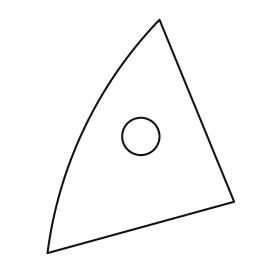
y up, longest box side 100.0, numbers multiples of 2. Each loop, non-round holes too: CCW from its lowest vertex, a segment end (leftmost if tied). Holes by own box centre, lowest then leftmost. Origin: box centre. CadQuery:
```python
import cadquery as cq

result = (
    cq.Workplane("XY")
    .moveTo(-40.0, -50.0)
    .lineTo(40.0, -28.0)
    .lineTo(8.0, 50.0)
    .threePointArc((-24.0, 4.0), (-40.0, -50.0))
    .close()
    .moveTo(0.0, 0.0)
    .circle(8.0)
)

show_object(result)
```